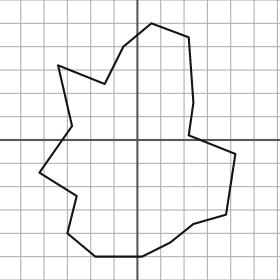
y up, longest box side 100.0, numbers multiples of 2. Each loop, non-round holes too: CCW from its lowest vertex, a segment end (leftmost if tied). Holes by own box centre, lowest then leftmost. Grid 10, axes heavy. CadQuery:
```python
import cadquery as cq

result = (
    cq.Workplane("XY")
    .moveTo(-18.0, -50.0)
    .lineTo(2.0, -50.0)
    .lineTo(14.0, -44.0)
    .lineTo(24.0, -36.0)
    .lineTo(38.0, -32.0)
    .lineTo(42.0, -6.0)
    .lineTo(22.0, 2.0)
    .lineTo(24.0, 16.0)
    .lineTo(22.0, 44.0)
    .lineTo(6.0, 50.0)
    .lineTo(-6.0, 40.0)
    .lineTo(-14.0, 24.0)
    .lineTo(-34.0, 32.0)
    .lineTo(-28.0, 6.0)
    .lineTo(-42.0, -14.0)
    .lineTo(-26.0, -24.0)
    .lineTo(-30.0, -40.0)
    .close()
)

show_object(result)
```